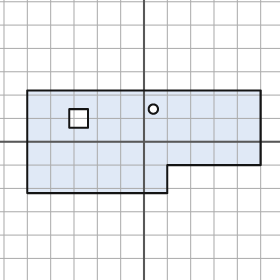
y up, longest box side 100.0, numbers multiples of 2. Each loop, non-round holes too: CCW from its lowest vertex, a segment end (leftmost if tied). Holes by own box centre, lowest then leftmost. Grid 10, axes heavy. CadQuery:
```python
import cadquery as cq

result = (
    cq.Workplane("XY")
    .moveTo(-50.0, -22.0)
    .lineTo(10.0, -22.0)
    .lineTo(10.0, -10.0)
    .lineTo(50.0, -10.0)
    .lineTo(50.0, 22.0)
    .lineTo(-50.0, 22.0)
    .close()
    .moveTo(-32.0, 6.0)
    .lineTo(-24.0, 6.0)
    .lineTo(-24.0, 14.0)
    .lineTo(-32.0, 14.0)
    .close()
    .moveTo(4.0, 14.0)
    .circle(2.0)
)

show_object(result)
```